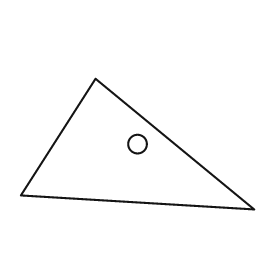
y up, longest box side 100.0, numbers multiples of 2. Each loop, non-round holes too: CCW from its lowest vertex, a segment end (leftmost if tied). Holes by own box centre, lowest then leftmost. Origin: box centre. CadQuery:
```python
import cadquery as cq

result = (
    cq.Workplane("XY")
    .moveTo(50.0, -28.0)
    .lineTo(-18.0, 28.0)
    .lineTo(-50.0, -22.0)
    .close()
    .moveTo(0.0, 0.0)
    .circle(4.0)
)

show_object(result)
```